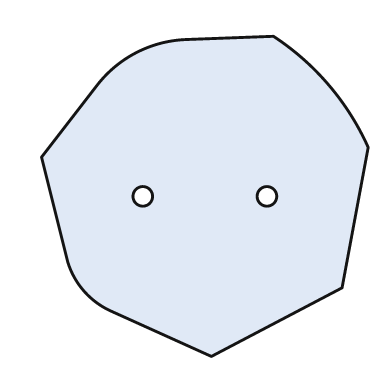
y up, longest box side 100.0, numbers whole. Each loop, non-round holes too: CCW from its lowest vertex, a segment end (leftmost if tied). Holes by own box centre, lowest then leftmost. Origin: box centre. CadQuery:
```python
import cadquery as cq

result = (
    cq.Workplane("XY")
    .moveTo(2.0, -49.0)
    .lineTo(42.0, -28.0)
    .lineTo(50.0, 15.0)
    .threePointArc((38.0, 34.0), (21.0, 49.0))
    .lineTo(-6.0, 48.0)
    .threePointArc((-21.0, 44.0), (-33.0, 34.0))
    .lineTo(-50.0, 12.0)
    .lineTo(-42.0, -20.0)
    .threePointArc((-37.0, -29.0), (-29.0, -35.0))
    .close()
    .moveTo(-19.0, 0.0)
    .circle(3.0)
    .moveTo(19.0, 0.0)
    .circle(3.0)
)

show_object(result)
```